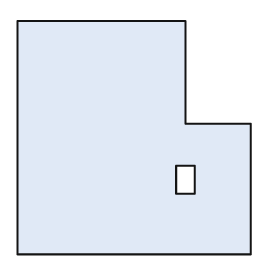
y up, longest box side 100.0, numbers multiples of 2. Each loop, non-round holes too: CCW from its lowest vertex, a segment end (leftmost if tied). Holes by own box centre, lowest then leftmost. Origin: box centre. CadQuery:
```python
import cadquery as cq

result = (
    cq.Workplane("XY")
    .moveTo(-50.0, -50.0)
    .lineTo(50.0, -50.0)
    .lineTo(50.0, 6.0)
    .lineTo(22.0, 6.0)
    .lineTo(22.0, 50.0)
    .lineTo(-50.0, 50.0)
    .close()
    .moveTo(18.0, -24.0)
    .lineTo(26.0, -24.0)
    .lineTo(26.0, -12.0)
    .lineTo(18.0, -12.0)
    .close()
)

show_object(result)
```